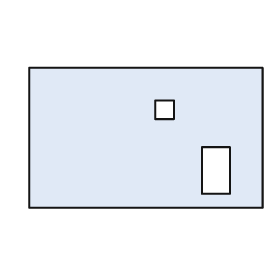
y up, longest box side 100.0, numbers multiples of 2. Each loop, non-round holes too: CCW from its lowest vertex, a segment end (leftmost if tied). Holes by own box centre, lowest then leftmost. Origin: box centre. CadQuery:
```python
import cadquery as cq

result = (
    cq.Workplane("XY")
    .moveTo(-50.0, -30.0)
    .lineTo(50.0, -30.0)
    .lineTo(50.0, 30.0)
    .lineTo(-50.0, 30.0)
    .close()
    .moveTo(24.0, -24.0)
    .lineTo(36.0, -24.0)
    .lineTo(36.0, -4.0)
    .lineTo(24.0, -4.0)
    .close()
    .moveTo(4.0, 8.0)
    .lineTo(12.0, 8.0)
    .lineTo(12.0, 16.0)
    .lineTo(4.0, 16.0)
    .close()
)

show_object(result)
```